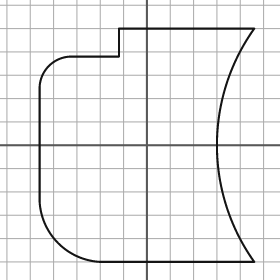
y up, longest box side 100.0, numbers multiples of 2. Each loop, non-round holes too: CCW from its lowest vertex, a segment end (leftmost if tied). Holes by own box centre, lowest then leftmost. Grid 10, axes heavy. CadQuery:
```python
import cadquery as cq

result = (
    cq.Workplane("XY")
    .moveTo(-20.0, -50.0)
    .lineTo(46.0, -50.0)
    .threePointArc((30.0, 0.0), (46.0, 50.0))
    .lineTo(-12.0, 50.0)
    .lineTo(-12.0, 38.0)
    .lineTo(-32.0, 38.0)
    .threePointArc((-42.0, 34.0), (-46.0, 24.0))
    .lineTo(-46.0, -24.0)
    .threePointArc((-38.0, -42.0), (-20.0, -50.0))
    .close()
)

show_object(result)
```